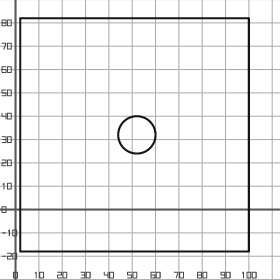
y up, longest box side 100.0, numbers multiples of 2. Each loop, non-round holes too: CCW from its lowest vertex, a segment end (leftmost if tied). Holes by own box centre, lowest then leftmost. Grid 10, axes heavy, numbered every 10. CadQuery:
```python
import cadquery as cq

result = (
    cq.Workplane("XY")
    .moveTo(2.0, -18.0)
    .lineTo(100.0, -18.0)
    .lineTo(100.0, 82.0)
    .lineTo(2.0, 82.0)
    .close()
    .moveTo(52.0, 32.0)
    .circle(8.0)
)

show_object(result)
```